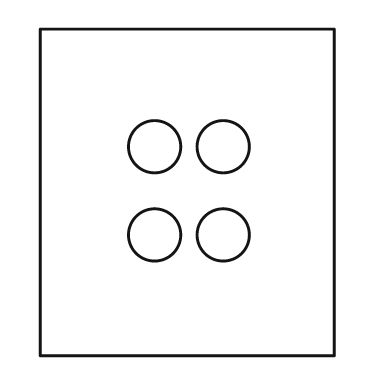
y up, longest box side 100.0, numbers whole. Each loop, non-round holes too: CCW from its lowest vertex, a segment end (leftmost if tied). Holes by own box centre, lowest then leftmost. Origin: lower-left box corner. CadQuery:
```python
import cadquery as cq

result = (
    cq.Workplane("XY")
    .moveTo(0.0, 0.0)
    .lineTo(90.0, 0.0)
    .lineTo(90.0, 100.0)
    .lineTo(0.0, 100.0)
    .close()
    .moveTo(35.0, 37.0)
    .circle(8.0)
    .moveTo(56.0, 37.0)
    .circle(8.0)
    .moveTo(35.0, 64.0)
    .circle(8.0)
    .moveTo(56.0, 64.0)
    .circle(8.0)
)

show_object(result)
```